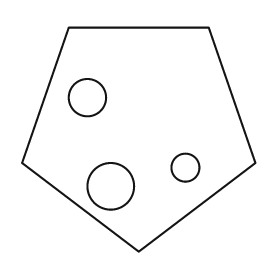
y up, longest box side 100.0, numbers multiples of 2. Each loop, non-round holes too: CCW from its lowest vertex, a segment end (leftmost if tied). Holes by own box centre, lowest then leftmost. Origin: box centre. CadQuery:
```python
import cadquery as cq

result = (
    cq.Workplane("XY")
    .moveTo(0.0, -48.0)
    .lineTo(50.0, -10.0)
    .lineTo(30.0, 48.0)
    .lineTo(-30.0, 48.0)
    .lineTo(-50.0, -10.0)
    .close()
    .moveTo(-12.0, -20.0)
    .circle(10.0)
    .moveTo(20.0, -12.0)
    .circle(6.0)
    .moveTo(-22.0, 18.0)
    .circle(8.0)
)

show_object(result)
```